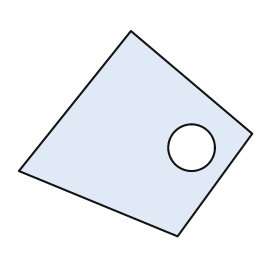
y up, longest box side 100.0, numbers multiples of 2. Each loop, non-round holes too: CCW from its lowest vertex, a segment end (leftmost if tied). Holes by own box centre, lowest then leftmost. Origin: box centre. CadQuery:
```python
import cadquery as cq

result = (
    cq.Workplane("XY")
    .moveTo(18.0, -44.0)
    .lineTo(50.0, 0.0)
    .lineTo(-2.0, 44.0)
    .lineTo(-50.0, -16.0)
    .close()
    .moveTo(24.0, -6.0)
    .circle(10.0)
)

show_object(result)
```